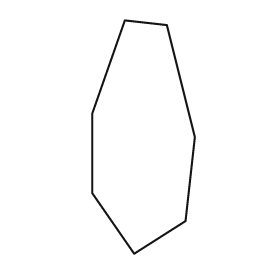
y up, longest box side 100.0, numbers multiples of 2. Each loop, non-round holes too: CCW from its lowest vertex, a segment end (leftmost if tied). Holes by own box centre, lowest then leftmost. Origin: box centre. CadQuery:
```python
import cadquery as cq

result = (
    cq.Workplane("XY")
    .moveTo(-4.0, -50.0)
    .lineTo(18.0, -36.0)
    .lineTo(22.0, 0.0)
    .lineTo(10.0, 48.0)
    .lineTo(-8.0, 50.0)
    .lineTo(-22.0, 10.0)
    .lineTo(-22.0, -24.0)
    .close()
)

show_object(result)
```